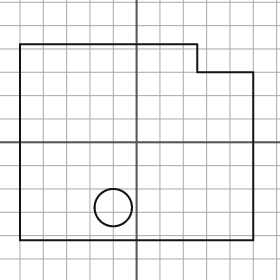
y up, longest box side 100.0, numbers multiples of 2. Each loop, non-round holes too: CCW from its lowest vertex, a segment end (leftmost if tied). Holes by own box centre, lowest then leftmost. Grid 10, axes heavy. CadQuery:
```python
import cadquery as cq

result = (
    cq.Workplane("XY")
    .moveTo(-50.0, -42.0)
    .lineTo(50.0, -42.0)
    .lineTo(50.0, 30.0)
    .lineTo(26.0, 30.0)
    .lineTo(26.0, 42.0)
    .lineTo(-50.0, 42.0)
    .close()
    .moveTo(-10.0, -28.0)
    .circle(8.0)
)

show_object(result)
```